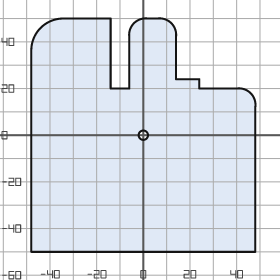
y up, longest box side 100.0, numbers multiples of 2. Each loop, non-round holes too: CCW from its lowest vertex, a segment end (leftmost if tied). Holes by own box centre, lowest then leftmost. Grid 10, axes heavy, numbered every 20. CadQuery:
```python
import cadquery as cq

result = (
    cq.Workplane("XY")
    .moveTo(-48.0, -50.0)
    .lineTo(48.0, -50.0)
    .lineTo(48.0, 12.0)
    .threePointArc((46.0, 18.0), (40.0, 20.0))
    .lineTo(24.0, 20.0)
    .lineTo(24.0, 24.0)
    .lineTo(14.0, 24.0)
    .lineTo(14.0, 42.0)
    .threePointArc((12.0, 48.0), (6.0, 50.0))
    .lineTo(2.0, 50.0)
    .threePointArc((-4.0, 48.0), (-6.0, 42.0))
    .lineTo(-6.0, 20.0)
    .lineTo(-14.0, 20.0)
    .lineTo(-14.0, 50.0)
    .lineTo(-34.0, 50.0)
    .threePointArc((-44.0, 46.0), (-48.0, 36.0))
    .close()
    .moveTo(0.0, 0.0)
    .circle(2.0)
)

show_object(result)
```